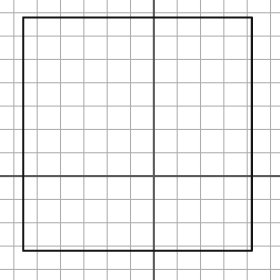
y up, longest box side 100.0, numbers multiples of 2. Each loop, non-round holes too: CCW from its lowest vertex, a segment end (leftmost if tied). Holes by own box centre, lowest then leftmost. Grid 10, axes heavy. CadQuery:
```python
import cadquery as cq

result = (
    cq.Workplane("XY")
    .moveTo(-56.0, -32.0)
    .lineTo(42.0, -32.0)
    .lineTo(42.0, 68.0)
    .lineTo(-56.0, 68.0)
    .close()
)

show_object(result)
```